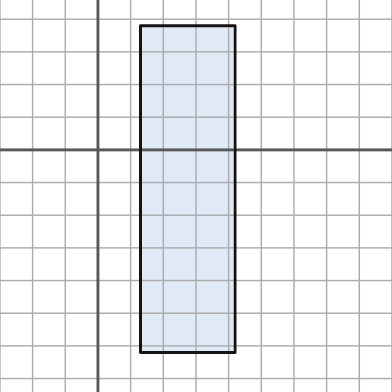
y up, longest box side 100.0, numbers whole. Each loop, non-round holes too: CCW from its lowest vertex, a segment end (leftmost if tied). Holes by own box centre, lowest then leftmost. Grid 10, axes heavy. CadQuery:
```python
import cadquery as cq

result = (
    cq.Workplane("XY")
    .moveTo(13.0, -62.0)
    .lineTo(42.0, -62.0)
    .lineTo(42.0, 38.0)
    .lineTo(13.0, 38.0)
    .close()
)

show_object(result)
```